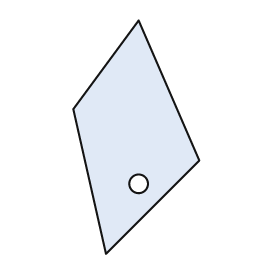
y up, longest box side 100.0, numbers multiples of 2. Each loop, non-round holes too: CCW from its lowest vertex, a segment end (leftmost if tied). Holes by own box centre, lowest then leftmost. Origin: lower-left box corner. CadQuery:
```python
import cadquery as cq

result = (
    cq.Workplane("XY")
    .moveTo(14.0, 0.0)
    .lineTo(54.0, 40.0)
    .lineTo(28.0, 100.0)
    .lineTo(0.0, 62.0)
    .close()
    .moveTo(28.0, 30.0)
    .circle(4.0)
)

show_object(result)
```